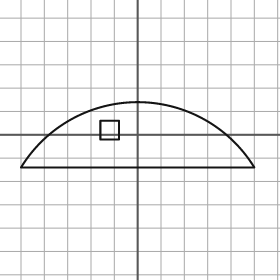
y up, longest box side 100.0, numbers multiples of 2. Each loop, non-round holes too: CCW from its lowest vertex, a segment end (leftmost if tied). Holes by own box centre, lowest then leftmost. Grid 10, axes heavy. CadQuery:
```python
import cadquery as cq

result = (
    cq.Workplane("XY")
    .moveTo(-50.0, -14.0)
    .lineTo(50.0, -14.0)
    .threePointArc((0.0, 14.0), (-50.0, -14.0))
    .close()
    .moveTo(-16.0, -2.0)
    .lineTo(-8.0, -2.0)
    .lineTo(-8.0, 6.0)
    .lineTo(-16.0, 6.0)
    .close()
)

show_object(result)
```